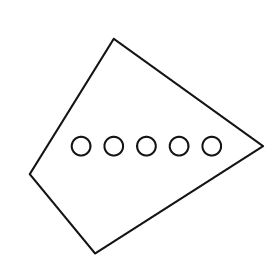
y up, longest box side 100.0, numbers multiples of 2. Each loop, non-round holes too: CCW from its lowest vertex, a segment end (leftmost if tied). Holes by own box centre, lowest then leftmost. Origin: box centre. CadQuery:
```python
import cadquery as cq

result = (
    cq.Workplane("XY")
    .moveTo(-22.0, -46.0)
    .lineTo(50.0, 0.0)
    .lineTo(-14.0, 46.0)
    .lineTo(-50.0, -12.0)
    .close()
    .moveTo(-28.0, 0.0)
    .circle(4.0)
    .moveTo(-14.0, 0.0)
    .circle(4.0)
    .moveTo(0.0, 0.0)
    .circle(4.0)
    .moveTo(14.0, 0.0)
    .circle(4.0)
    .moveTo(28.0, 0.0)
    .circle(4.0)
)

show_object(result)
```